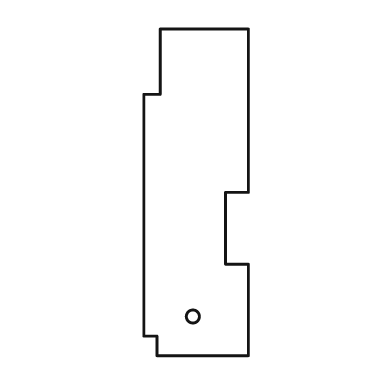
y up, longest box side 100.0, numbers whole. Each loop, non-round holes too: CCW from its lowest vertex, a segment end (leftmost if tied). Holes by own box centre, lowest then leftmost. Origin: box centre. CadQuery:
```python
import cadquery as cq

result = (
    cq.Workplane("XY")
    .moveTo(-12.0, -50.0)
    .lineTo(16.0, -50.0)
    .lineTo(16.0, -22.0)
    .lineTo(9.0, -22.0)
    .lineTo(9.0, 0.0)
    .lineTo(16.0, 0.0)
    .lineTo(16.0, 50.0)
    .lineTo(-11.0, 50.0)
    .lineTo(-11.0, 30.0)
    .lineTo(-16.0, 30.0)
    .lineTo(-16.0, -44.0)
    .lineTo(-12.0, -44.0)
    .close()
    .moveTo(-1.0, -38.0)
    .circle(2.0)
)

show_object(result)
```